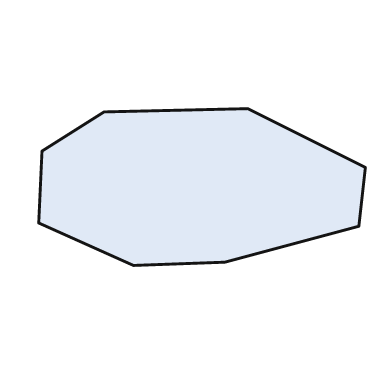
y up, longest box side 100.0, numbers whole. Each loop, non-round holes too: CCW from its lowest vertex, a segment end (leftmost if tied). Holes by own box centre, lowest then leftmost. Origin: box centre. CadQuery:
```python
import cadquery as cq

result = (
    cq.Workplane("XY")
    .moveTo(-21.0, -24.0)
    .lineTo(7.0, -23.0)
    .lineTo(48.0, -12.0)
    .lineTo(50.0, 6.0)
    .lineTo(14.0, 24.0)
    .lineTo(-30.0, 23.0)
    .lineTo(-49.0, 11.0)
    .lineTo(-50.0, -11.0)
    .close()
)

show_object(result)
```